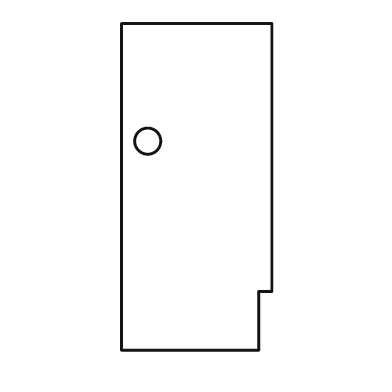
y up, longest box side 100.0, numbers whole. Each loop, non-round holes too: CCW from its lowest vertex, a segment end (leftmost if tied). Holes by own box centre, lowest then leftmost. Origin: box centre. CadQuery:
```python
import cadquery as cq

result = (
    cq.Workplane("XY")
    .moveTo(-23.0, -50.0)
    .lineTo(19.0, -50.0)
    .lineTo(19.0, -32.0)
    .lineTo(23.0, -32.0)
    .lineTo(23.0, 50.0)
    .lineTo(-23.0, 50.0)
    .close()
    .moveTo(-15.0, 14.0)
    .circle(4.0)
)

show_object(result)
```